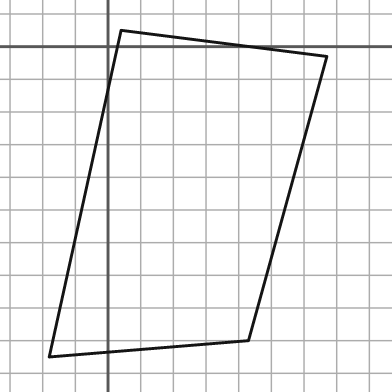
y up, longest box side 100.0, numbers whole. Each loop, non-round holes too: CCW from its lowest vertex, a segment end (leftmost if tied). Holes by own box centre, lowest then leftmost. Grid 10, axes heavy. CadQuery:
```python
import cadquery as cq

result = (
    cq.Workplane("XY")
    .moveTo(-18.0, -95.0)
    .lineTo(43.0, -90.0)
    .lineTo(67.0, -3.0)
    .lineTo(4.0, 5.0)
    .close()
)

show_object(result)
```